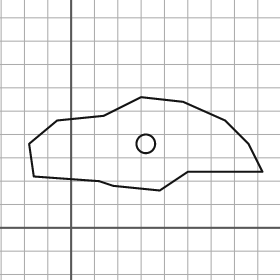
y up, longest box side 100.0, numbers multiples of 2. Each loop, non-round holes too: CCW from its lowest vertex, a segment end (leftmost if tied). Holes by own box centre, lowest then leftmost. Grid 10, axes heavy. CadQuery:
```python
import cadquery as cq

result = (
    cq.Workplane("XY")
    .moveTo(38.0, 16.0)
    .lineTo(50.0, 24.0)
    .lineTo(82.0, 24.0)
    .lineTo(76.0, 36.0)
    .lineTo(66.0, 46.0)
    .lineTo(48.0, 54.0)
    .lineTo(30.0, 56.0)
    .lineTo(14.0, 48.0)
    .lineTo(-6.0, 46.0)
    .lineTo(-18.0, 36.0)
    .lineTo(-16.0, 22.0)
    .lineTo(12.0, 20.0)
    .lineTo(18.0, 18.0)
    .close()
    .moveTo(32.0, 36.0)
    .circle(4.0)
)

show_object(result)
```